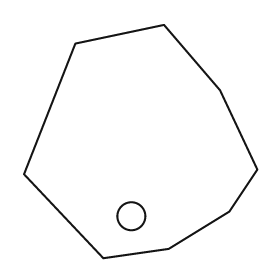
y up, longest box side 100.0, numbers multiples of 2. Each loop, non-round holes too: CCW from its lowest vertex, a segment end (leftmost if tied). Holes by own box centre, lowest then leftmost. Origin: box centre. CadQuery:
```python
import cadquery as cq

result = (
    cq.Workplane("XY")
    .moveTo(-16.0, -50.0)
    .lineTo(12.0, -46.0)
    .lineTo(38.0, -30.0)
    .lineTo(50.0, -12.0)
    .lineTo(34.0, 22.0)
    .lineTo(10.0, 50.0)
    .lineTo(-28.0, 42.0)
    .lineTo(-50.0, -14.0)
    .close()
    .moveTo(-4.0, -32.0)
    .circle(6.0)
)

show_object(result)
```